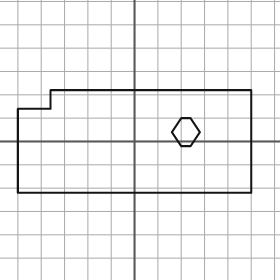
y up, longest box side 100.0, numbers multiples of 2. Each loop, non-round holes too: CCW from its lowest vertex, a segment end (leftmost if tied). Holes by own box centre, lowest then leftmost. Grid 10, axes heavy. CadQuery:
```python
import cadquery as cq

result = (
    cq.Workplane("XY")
    .moveTo(-50.0, -22.0)
    .lineTo(50.0, -22.0)
    .lineTo(50.0, 22.0)
    .lineTo(-36.0, 22.0)
    .lineTo(-36.0, 14.0)
    .lineTo(-50.0, 14.0)
    .close()
    .moveTo(20.0, -2.0)
    .lineTo(24.0, -2.0)
    .lineTo(28.0, 4.0)
    .lineTo(24.0, 10.0)
    .lineTo(20.0, 10.0)
    .lineTo(16.0, 4.0)
    .close()
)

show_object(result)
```